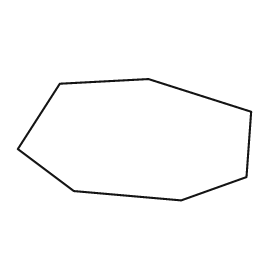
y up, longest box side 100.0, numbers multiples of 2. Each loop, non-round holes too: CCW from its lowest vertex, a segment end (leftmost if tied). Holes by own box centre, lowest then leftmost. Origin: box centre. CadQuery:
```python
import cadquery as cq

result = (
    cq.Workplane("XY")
    .moveTo(20.0, -26.0)
    .lineTo(48.0, -16.0)
    .lineTo(50.0, 12.0)
    .lineTo(6.0, 26.0)
    .lineTo(-32.0, 24.0)
    .lineTo(-50.0, -4.0)
    .lineTo(-26.0, -22.0)
    .close()
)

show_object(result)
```